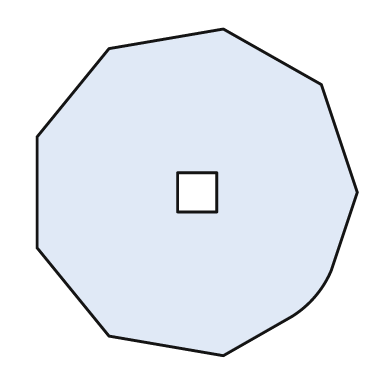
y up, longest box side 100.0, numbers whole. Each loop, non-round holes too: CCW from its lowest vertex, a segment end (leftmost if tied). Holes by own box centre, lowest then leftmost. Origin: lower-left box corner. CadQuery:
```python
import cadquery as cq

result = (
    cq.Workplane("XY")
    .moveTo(57.0, 0.0)
    .lineTo(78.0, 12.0)
    .threePointArc((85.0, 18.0), (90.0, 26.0))
    .lineTo(98.0, 50.0)
    .lineTo(87.0, 83.0)
    .lineTo(57.0, 100.0)
    .lineTo(22.0, 94.0)
    .lineTo(0.0, 67.0)
    .lineTo(0.0, 33.0)
    .lineTo(22.0, 6.0)
    .close()
    .moveTo(43.0, 44.0)
    .lineTo(55.0, 44.0)
    .lineTo(55.0, 56.0)
    .lineTo(43.0, 56.0)
    .close()
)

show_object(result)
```